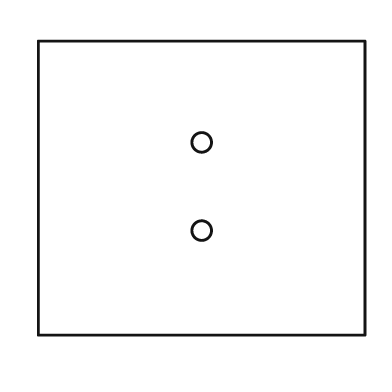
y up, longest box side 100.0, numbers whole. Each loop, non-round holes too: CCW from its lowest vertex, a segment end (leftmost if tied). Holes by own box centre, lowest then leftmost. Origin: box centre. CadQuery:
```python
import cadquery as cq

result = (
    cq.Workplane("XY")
    .moveTo(-50.0, -45.0)
    .lineTo(50.0, -45.0)
    .lineTo(50.0, 45.0)
    .lineTo(-50.0, 45.0)
    .close()
    .moveTo(0.0, -13.0)
    .circle(3.0)
    .moveTo(0.0, 14.0)
    .circle(3.0)
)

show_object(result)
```